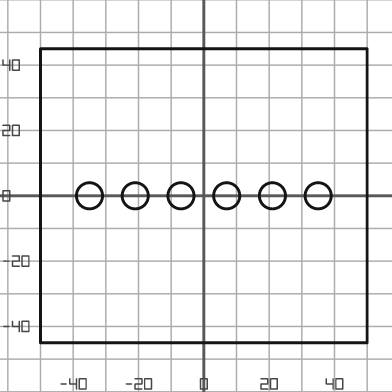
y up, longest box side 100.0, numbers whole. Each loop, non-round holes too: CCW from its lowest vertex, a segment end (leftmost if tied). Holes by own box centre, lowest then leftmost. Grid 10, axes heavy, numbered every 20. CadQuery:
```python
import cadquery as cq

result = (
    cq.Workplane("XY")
    .moveTo(-50.0, -45.0)
    .lineTo(50.0, -45.0)
    .lineTo(50.0, 45.0)
    .lineTo(-50.0, 45.0)
    .close()
    .moveTo(-35.0, 0.0)
    .circle(4.0)
    .moveTo(-21.0, 0.0)
    .circle(4.0)
    .moveTo(-7.0, 0.0)
    .circle(4.0)
    .moveTo(7.0, 0.0)
    .circle(4.0)
    .moveTo(21.0, 0.0)
    .circle(4.0)
    .moveTo(35.0, 0.0)
    .circle(4.0)
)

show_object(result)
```